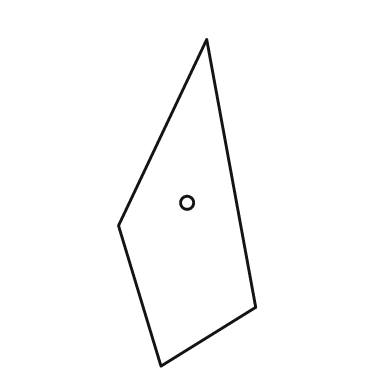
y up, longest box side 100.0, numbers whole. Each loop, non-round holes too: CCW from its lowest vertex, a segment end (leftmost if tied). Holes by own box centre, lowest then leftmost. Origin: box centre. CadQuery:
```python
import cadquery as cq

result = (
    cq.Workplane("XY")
    .moveTo(-8.0, -50.0)
    .lineTo(21.0, -32.0)
    .lineTo(6.0, 50.0)
    .lineTo(-21.0, -7.0)
    .close()
    .moveTo(0.0, 0.0)
    .circle(2.0)
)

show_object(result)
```